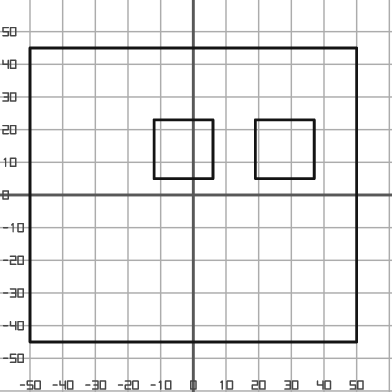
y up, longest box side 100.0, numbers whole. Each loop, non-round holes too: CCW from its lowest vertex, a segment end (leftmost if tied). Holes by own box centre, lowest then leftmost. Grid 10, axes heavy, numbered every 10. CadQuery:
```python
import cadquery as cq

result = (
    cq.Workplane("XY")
    .moveTo(-50.0, -45.0)
    .lineTo(50.0, -45.0)
    .lineTo(50.0, 45.0)
    .lineTo(-50.0, 45.0)
    .close()
    .moveTo(-12.0, 5.0)
    .lineTo(6.0, 5.0)
    .lineTo(6.0, 23.0)
    .lineTo(-12.0, 23.0)
    .close()
    .moveTo(19.0, 5.0)
    .lineTo(37.0, 5.0)
    .lineTo(37.0, 23.0)
    .lineTo(19.0, 23.0)
    .close()
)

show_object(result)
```